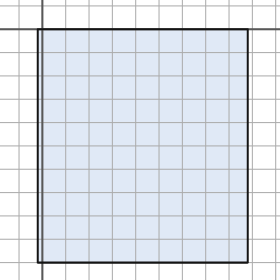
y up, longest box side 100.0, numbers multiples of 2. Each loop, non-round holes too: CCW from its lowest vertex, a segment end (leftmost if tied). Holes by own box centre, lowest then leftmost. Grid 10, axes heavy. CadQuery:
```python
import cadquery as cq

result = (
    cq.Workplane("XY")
    .moveTo(-2.0, -100.0)
    .lineTo(88.0, -100.0)
    .lineTo(88.0, 0.0)
    .lineTo(-2.0, 0.0)
    .close()
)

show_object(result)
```